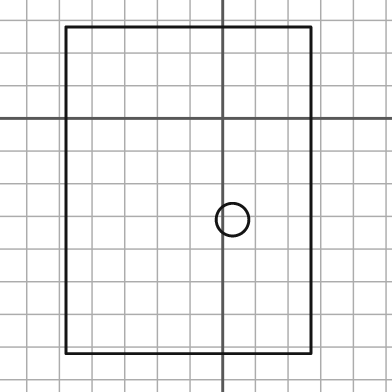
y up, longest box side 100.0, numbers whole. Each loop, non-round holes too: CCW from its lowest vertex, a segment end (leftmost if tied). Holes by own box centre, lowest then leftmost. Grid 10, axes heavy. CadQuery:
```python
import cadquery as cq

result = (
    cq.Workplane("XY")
    .moveTo(-48.0, -72.0)
    .lineTo(27.0, -72.0)
    .lineTo(27.0, 28.0)
    .lineTo(-48.0, 28.0)
    .close()
    .moveTo(3.0, -31.0)
    .circle(5.0)
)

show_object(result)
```